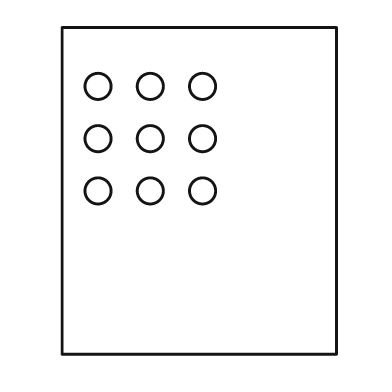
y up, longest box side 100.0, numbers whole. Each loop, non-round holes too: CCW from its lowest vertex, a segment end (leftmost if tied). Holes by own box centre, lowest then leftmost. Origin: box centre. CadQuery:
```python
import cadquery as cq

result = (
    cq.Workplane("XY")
    .moveTo(-42.0, -50.0)
    .lineTo(42.0, -50.0)
    .lineTo(42.0, 50.0)
    .lineTo(-42.0, 50.0)
    .close()
    .moveTo(-31.0, 0.0)
    .circle(4.0)
    .moveTo(-15.0, 0.0)
    .circle(4.0)
    .moveTo(1.0, 0.0)
    .circle(4.0)
    .moveTo(-31.0, 16.0)
    .circle(4.0)
    .moveTo(-15.0, 16.0)
    .circle(4.0)
    .moveTo(1.0, 16.0)
    .circle(4.0)
    .moveTo(-31.0, 32.0)
    .circle(4.0)
    .moveTo(-15.0, 32.0)
    .circle(4.0)
    .moveTo(1.0, 32.0)
    .circle(4.0)
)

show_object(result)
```